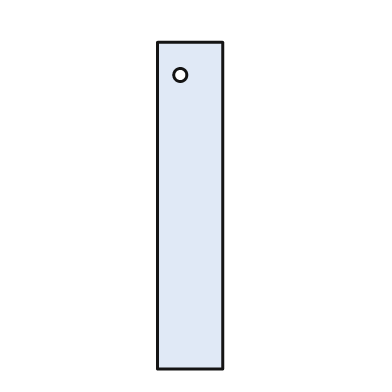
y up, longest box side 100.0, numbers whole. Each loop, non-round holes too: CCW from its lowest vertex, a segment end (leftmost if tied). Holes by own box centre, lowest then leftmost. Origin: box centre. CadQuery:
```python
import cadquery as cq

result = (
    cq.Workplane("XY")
    .moveTo(-10.0, -50.0)
    .lineTo(10.0, -50.0)
    .lineTo(10.0, 50.0)
    .lineTo(-10.0, 50.0)
    .close()
    .moveTo(-3.0, 40.0)
    .circle(2.0)
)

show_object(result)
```